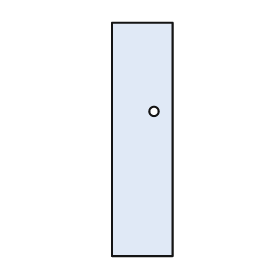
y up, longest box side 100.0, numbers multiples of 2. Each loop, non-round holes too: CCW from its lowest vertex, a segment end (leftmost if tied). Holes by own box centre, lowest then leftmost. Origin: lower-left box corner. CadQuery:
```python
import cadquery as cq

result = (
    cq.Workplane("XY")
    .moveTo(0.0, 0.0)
    .lineTo(26.0, 0.0)
    .lineTo(26.0, 100.0)
    .lineTo(0.0, 100.0)
    .close()
    .moveTo(18.0, 62.0)
    .circle(2.0)
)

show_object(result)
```